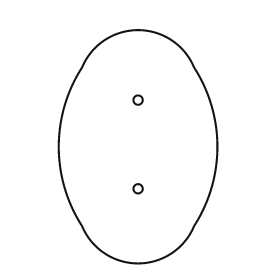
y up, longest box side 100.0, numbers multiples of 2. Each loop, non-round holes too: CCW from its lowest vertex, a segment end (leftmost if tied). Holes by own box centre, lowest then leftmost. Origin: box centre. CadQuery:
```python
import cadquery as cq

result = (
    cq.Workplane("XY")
    .moveTo(-24.0, -34.0)
    .threePointArc((0.0, -50.0), (24.0, -34.0))
    .threePointArc((34.0, 0.0), (24.0, 34.0))
    .threePointArc((0.0, 50.0), (-24.0, 34.0))
    .threePointArc((-34.0, 0.0), (-24.0, -34.0))
    .close()
    .moveTo(0.0, -18.0)
    .circle(2.0)
    .moveTo(0.0, 20.0)
    .circle(2.0)
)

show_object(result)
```